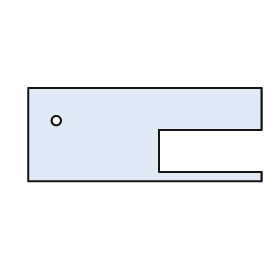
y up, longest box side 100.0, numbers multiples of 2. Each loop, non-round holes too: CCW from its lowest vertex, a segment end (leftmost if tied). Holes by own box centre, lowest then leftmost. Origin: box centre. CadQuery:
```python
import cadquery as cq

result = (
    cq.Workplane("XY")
    .moveTo(-50.0, -20.0)
    .lineTo(50.0, -20.0)
    .lineTo(50.0, -16.0)
    .lineTo(6.0, -16.0)
    .lineTo(6.0, 2.0)
    .lineTo(50.0, 2.0)
    .lineTo(50.0, 20.0)
    .lineTo(-50.0, 20.0)
    .close()
    .moveTo(-38.0, 6.0)
    .circle(2.0)
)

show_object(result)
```